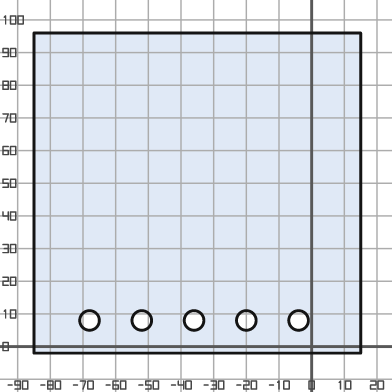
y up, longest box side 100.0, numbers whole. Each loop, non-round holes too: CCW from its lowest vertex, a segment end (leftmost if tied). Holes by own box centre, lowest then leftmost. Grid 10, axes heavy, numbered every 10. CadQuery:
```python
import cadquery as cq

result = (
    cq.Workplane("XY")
    .moveTo(-85.0, -2.0)
    .lineTo(15.0, -2.0)
    .lineTo(15.0, 96.0)
    .lineTo(-85.0, 96.0)
    .close()
    .moveTo(-68.0, 8.0)
    .circle(3.0)
    .moveTo(-52.0, 8.0)
    .circle(3.0)
    .moveTo(-36.0, 8.0)
    .circle(3.0)
    .moveTo(-20.0, 8.0)
    .circle(3.0)
    .moveTo(-4.0, 8.0)
    .circle(3.0)
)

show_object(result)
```